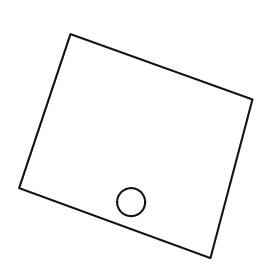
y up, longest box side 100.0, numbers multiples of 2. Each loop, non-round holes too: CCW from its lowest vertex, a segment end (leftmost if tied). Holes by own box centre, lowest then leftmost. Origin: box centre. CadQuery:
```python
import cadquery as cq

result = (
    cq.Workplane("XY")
    .moveTo(32.0, -48.0)
    .lineTo(50.0, 20.0)
    .lineTo(-28.0, 48.0)
    .lineTo(-50.0, -18.0)
    .close()
    .moveTo(-2.0, -24.0)
    .circle(6.0)
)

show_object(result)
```